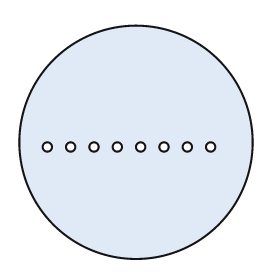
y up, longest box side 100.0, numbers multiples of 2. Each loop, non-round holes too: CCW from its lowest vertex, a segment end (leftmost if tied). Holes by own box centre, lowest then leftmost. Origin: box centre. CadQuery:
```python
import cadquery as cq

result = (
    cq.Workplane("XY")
    .moveTo(0.0, 0.0)
    .circle(50.0)
    .moveTo(-38.0, -2.0)
    .circle(2.0)
    .moveTo(-28.0, -2.0)
    .circle(2.0)
    .moveTo(-18.0, -2.0)
    .circle(2.0)
    .moveTo(-8.0, -2.0)
    .circle(2.0)
    .moveTo(2.0, -2.0)
    .circle(2.0)
    .moveTo(12.0, -2.0)
    .circle(2.0)
    .moveTo(22.0, -2.0)
    .circle(2.0)
    .moveTo(32.0, -2.0)
    .circle(2.0)
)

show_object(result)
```